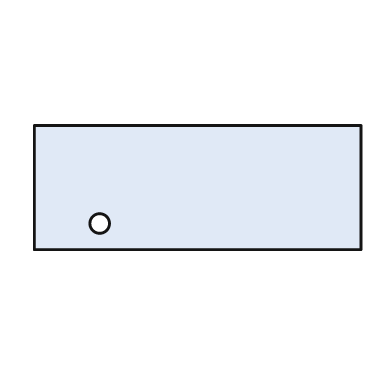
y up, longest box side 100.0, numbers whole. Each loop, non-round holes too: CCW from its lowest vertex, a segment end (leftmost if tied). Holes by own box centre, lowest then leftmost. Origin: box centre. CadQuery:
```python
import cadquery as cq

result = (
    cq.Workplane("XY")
    .moveTo(-50.0, -19.0)
    .lineTo(50.0, -19.0)
    .lineTo(50.0, 19.0)
    .lineTo(-50.0, 19.0)
    .close()
    .moveTo(-30.0, -11.0)
    .circle(3.0)
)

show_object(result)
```